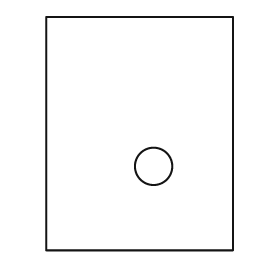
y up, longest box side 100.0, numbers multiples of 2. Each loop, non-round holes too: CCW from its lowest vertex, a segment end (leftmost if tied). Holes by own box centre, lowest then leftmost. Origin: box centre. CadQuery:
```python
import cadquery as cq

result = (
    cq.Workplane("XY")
    .moveTo(-40.0, -50.0)
    .lineTo(40.0, -50.0)
    .lineTo(40.0, 50.0)
    .lineTo(-40.0, 50.0)
    .close()
    .moveTo(6.0, -14.0)
    .circle(8.0)
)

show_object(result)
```